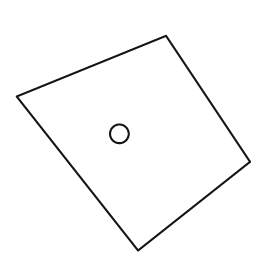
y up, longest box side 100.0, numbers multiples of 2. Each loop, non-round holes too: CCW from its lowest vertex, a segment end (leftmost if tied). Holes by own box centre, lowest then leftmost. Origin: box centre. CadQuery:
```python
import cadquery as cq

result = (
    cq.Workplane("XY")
    .moveTo(2.0, -46.0)
    .lineTo(50.0, -8.0)
    .lineTo(14.0, 46.0)
    .lineTo(-50.0, 20.0)
    .close()
    .moveTo(-6.0, 4.0)
    .circle(4.0)
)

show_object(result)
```